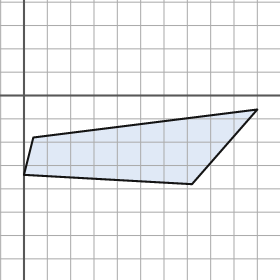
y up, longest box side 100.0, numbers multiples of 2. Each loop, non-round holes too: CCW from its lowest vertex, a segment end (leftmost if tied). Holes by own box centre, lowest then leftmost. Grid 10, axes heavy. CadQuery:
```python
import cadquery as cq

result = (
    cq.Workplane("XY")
    .moveTo(72.0, -38.0)
    .lineTo(100.0, -6.0)
    .lineTo(4.0, -18.0)
    .lineTo(0.0, -34.0)
    .close()
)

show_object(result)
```